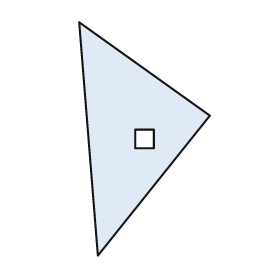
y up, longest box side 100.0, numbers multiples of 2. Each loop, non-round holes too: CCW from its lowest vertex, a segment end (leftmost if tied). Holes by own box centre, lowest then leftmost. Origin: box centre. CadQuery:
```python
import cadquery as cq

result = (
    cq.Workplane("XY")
    .moveTo(-20.0, -50.0)
    .lineTo(28.0, 10.0)
    .lineTo(-28.0, 50.0)
    .close()
    .moveTo(-4.0, -4.0)
    .lineTo(4.0, -4.0)
    .lineTo(4.0, 4.0)
    .lineTo(-4.0, 4.0)
    .close()
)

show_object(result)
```